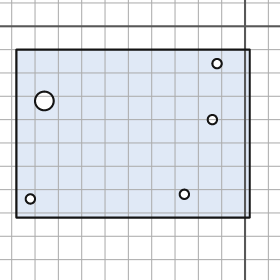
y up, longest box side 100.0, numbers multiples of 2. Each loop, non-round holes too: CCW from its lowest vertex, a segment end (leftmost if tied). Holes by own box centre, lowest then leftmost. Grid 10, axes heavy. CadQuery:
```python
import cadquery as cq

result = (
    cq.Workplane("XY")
    .moveTo(-98.0, -82.0)
    .lineTo(2.0, -82.0)
    .lineTo(2.0, -10.0)
    .lineTo(-98.0, -10.0)
    .close()
    .moveTo(-92.0, -74.0)
    .circle(2.0)
    .moveTo(-26.0, -72.0)
    .circle(2.0)
    .moveTo(-14.0, -40.0)
    .circle(2.0)
    .moveTo(-86.0, -32.0)
    .circle(4.0)
    .moveTo(-12.0, -16.0)
    .circle(2.0)
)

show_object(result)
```